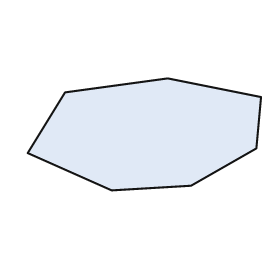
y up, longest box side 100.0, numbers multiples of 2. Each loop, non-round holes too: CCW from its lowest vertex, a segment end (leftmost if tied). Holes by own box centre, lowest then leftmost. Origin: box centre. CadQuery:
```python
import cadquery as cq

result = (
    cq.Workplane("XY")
    .moveTo(-14.0, -24.0)
    .lineTo(20.0, -22.0)
    .lineTo(48.0, -6.0)
    .lineTo(50.0, 16.0)
    .lineTo(10.0, 24.0)
    .lineTo(-34.0, 18.0)
    .lineTo(-50.0, -8.0)
    .close()
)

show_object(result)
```